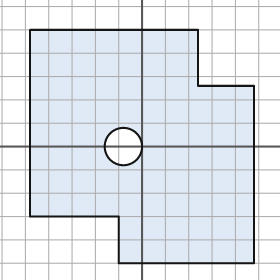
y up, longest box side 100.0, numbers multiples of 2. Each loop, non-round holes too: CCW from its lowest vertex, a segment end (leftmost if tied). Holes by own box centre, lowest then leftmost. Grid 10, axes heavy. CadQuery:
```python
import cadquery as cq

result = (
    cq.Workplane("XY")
    .moveTo(-10.0, -50.0)
    .lineTo(48.0, -50.0)
    .lineTo(48.0, 26.0)
    .lineTo(24.0, 26.0)
    .lineTo(24.0, 50.0)
    .lineTo(-48.0, 50.0)
    .lineTo(-48.0, -30.0)
    .lineTo(-10.0, -30.0)
    .close()
    .moveTo(-8.0, 0.0)
    .circle(8.0)
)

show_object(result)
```